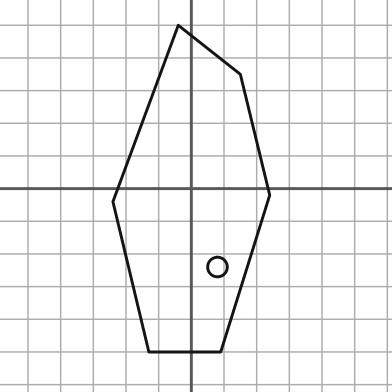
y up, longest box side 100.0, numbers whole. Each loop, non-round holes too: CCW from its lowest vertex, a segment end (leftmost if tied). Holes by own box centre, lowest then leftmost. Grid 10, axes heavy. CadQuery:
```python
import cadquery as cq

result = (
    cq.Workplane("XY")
    .moveTo(-13.0, -50.0)
    .lineTo(9.0, -50.0)
    .lineTo(24.0, -2.0)
    .lineTo(15.0, 35.0)
    .lineTo(-4.0, 50.0)
    .lineTo(-24.0, -4.0)
    .close()
    .moveTo(8.0, -24.0)
    .circle(3.0)
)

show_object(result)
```